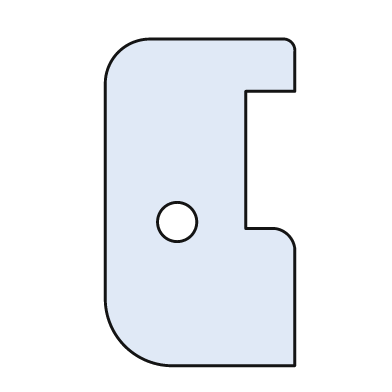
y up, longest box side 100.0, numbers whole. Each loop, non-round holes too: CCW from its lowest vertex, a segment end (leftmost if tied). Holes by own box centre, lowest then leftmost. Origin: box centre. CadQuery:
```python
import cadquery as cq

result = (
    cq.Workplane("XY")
    .moveTo(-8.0, -50.0)
    .lineTo(29.0, -50.0)
    .lineTo(29.0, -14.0)
    .threePointArc((27.0, -10.0), (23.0, -8.0))
    .lineTo(14.0, -8.0)
    .lineTo(14.0, 34.0)
    .lineTo(29.0, 34.0)
    .lineTo(29.0, 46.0)
    .threePointArc((28.0, 49.0), (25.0, 50.0))
    .lineTo(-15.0, 50.0)
    .threePointArc((-25.0, 46.0), (-29.0, 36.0))
    .lineTo(-29.0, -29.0)
    .threePointArc((-23.0, -44.0), (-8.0, -50.0))
    .close()
    .moveTo(-7.0, -6.0)
    .circle(6.0)
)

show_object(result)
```